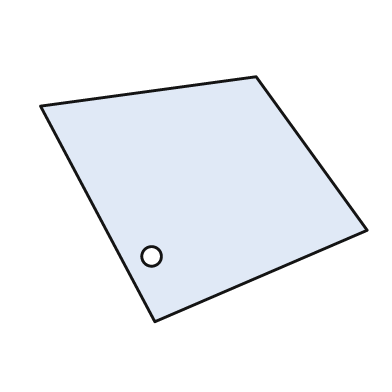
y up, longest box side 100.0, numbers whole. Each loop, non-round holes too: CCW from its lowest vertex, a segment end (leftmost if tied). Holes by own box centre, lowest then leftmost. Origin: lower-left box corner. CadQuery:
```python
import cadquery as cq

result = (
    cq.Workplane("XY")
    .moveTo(35.0, 0.0)
    .lineTo(100.0, 28.0)
    .lineTo(66.0, 75.0)
    .lineTo(0.0, 66.0)
    .close()
    .moveTo(34.0, 20.0)
    .circle(3.0)
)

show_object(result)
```